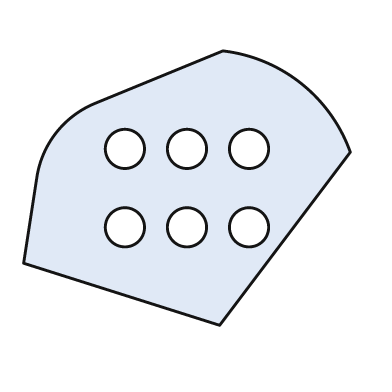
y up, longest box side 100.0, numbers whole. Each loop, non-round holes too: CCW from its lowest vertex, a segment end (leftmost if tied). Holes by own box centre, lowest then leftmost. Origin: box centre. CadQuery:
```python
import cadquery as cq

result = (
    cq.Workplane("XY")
    .moveTo(10.0, -42.0)
    .lineTo(50.0, 11.0)
    .threePointArc((35.0, 32.0), (11.0, 42.0))
    .lineTo(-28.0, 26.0)
    .threePointArc((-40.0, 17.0), (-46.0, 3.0))
    .lineTo(-50.0, -23.0)
    .close()
    .moveTo(-19.0, -12.0)
    .circle(6.0)
    .moveTo(0.0, -12.0)
    .circle(6.0)
    .moveTo(19.0, -12.0)
    .circle(6.0)
    .moveTo(-19.0, 12.0)
    .circle(6.0)
    .moveTo(0.0, 12.0)
    .circle(6.0)
    .moveTo(19.0, 12.0)
    .circle(6.0)
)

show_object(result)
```